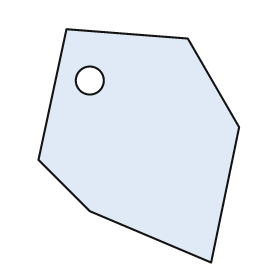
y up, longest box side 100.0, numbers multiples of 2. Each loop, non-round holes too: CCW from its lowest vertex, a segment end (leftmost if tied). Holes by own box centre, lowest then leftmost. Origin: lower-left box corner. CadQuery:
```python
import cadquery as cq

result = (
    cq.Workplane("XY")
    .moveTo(74.0, 0.0)
    .lineTo(86.0, 58.0)
    .lineTo(64.0, 96.0)
    .lineTo(12.0, 100.0)
    .lineTo(0.0, 44.0)
    .lineTo(22.0, 22.0)
    .close()
    .moveTo(22.0, 78.0)
    .circle(6.0)
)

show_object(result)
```